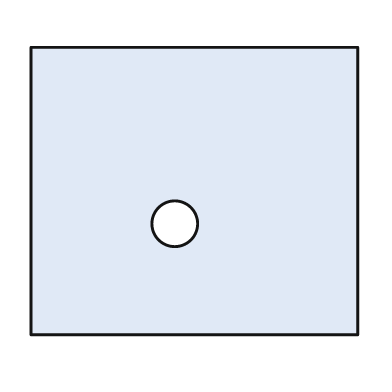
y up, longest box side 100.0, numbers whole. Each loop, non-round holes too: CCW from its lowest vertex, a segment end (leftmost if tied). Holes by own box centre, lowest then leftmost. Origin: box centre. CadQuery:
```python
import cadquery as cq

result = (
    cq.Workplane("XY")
    .moveTo(-50.0, -44.0)
    .lineTo(50.0, -44.0)
    .lineTo(50.0, 44.0)
    .lineTo(-50.0, 44.0)
    .close()
    .moveTo(-6.0, -10.0)
    .circle(7.0)
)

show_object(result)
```